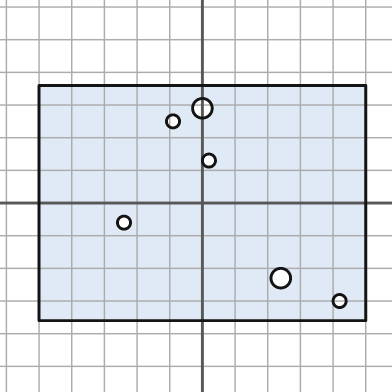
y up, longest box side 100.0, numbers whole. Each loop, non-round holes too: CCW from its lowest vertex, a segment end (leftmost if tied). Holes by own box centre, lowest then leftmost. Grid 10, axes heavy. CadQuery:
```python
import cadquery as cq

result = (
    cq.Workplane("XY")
    .moveTo(-50.0, -36.0)
    .lineTo(50.0, -36.0)
    .lineTo(50.0, 36.0)
    .lineTo(-50.0, 36.0)
    .close()
    .moveTo(42.0, -30.0)
    .circle(2.0)
    .moveTo(24.0, -23.0)
    .circle(3.0)
    .moveTo(-24.0, -6.0)
    .circle(2.0)
    .moveTo(2.0, 13.0)
    .circle(2.0)
    .moveTo(-9.0, 25.0)
    .circle(2.0)
    .moveTo(0.0, 29.0)
    .circle(3.0)
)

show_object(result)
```